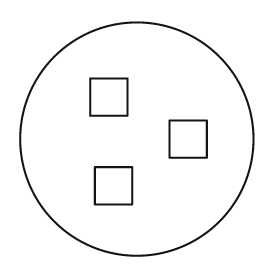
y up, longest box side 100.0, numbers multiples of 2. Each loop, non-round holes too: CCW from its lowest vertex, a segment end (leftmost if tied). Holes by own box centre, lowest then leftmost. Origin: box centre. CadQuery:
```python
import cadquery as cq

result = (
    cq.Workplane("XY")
    .moveTo(0.0, 0.0)
    .circle(50.0)
    .moveTo(-18.0, -28.0)
    .lineTo(-2.0, -28.0)
    .lineTo(-2.0, -12.0)
    .lineTo(-18.0, -12.0)
    .close()
    .moveTo(14.0, -8.0)
    .lineTo(30.0, -8.0)
    .lineTo(30.0, 8.0)
    .lineTo(14.0, 8.0)
    .close()
    .moveTo(-20.0, 10.0)
    .lineTo(-4.0, 10.0)
    .lineTo(-4.0, 26.0)
    .lineTo(-20.0, 26.0)
    .close()
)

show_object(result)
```